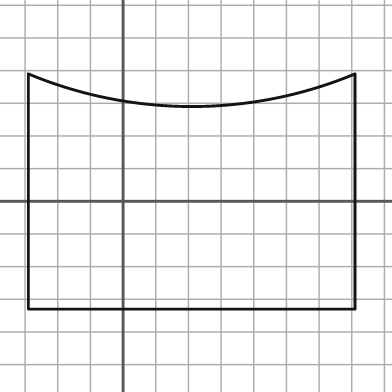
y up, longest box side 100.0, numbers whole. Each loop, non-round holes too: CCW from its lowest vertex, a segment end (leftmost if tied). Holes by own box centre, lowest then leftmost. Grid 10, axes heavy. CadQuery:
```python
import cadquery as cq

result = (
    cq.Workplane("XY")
    .moveTo(-29.0, -33.0)
    .lineTo(71.0, -33.0)
    .lineTo(71.0, 39.0)
    .threePointArc((21.0, 29.0), (-29.0, 39.0))
    .close()
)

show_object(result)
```